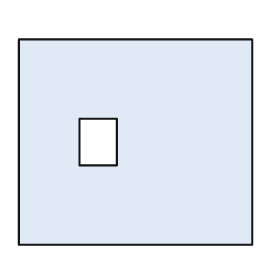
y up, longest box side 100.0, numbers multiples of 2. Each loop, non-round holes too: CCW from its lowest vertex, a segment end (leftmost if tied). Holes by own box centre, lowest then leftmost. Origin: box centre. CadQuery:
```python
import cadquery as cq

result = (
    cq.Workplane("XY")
    .moveTo(-50.0, -44.0)
    .lineTo(50.0, -44.0)
    .lineTo(50.0, 44.0)
    .lineTo(-50.0, 44.0)
    .close()
    .moveTo(-24.0, -10.0)
    .lineTo(-8.0, -10.0)
    .lineTo(-8.0, 10.0)
    .lineTo(-24.0, 10.0)
    .close()
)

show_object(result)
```